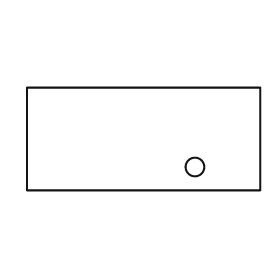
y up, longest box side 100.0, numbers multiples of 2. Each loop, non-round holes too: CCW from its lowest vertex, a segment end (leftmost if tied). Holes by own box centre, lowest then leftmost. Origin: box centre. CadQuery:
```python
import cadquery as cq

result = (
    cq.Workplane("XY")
    .moveTo(-50.0, -22.0)
    .lineTo(50.0, -22.0)
    .lineTo(50.0, 22.0)
    .lineTo(-50.0, 22.0)
    .close()
    .moveTo(22.0, -12.0)
    .circle(4.0)
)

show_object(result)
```